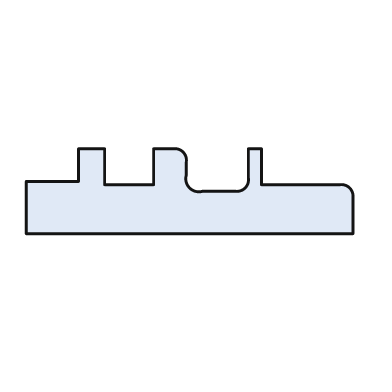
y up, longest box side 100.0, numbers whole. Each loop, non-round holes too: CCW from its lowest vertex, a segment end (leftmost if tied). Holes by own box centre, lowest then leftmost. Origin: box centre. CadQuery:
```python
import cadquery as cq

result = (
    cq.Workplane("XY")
    .moveTo(-50.0, -13.0)
    .lineTo(50.0, -13.0)
    .lineTo(50.0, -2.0)
    .threePointArc((49.0, 1.0), (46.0, 2.0))
    .lineTo(22.0, 2.0)
    .lineTo(22.0, 13.0)
    .lineTo(18.0, 13.0)
    .lineTo(18.0, 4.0)
    .threePointArc((17.0, 1.0), (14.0, 0.0))
    .lineTo(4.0, 0.0)
    .threePointArc((0.0, 1.0), (-1.0, 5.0))
    .lineTo(-1.0, 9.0)
    .threePointArc((-2.0, 12.0), (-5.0, 13.0))
    .lineTo(-11.0, 13.0)
    .lineTo(-11.0, 2.0)
    .lineTo(-26.0, 2.0)
    .lineTo(-26.0, 13.0)
    .lineTo(-34.0, 13.0)
    .lineTo(-34.0, 3.0)
    .lineTo(-50.0, 3.0)
    .close()
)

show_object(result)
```